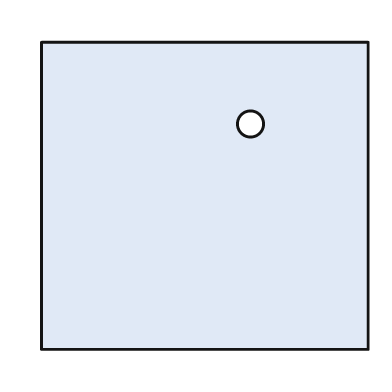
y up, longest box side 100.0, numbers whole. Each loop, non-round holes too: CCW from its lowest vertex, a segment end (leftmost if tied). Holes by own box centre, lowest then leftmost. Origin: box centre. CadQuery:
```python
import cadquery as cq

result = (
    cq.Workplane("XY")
    .moveTo(-50.0, -47.0)
    .lineTo(50.0, -47.0)
    .lineTo(50.0, 47.0)
    .lineTo(-50.0, 47.0)
    .close()
    .moveTo(14.0, 22.0)
    .circle(4.0)
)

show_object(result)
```